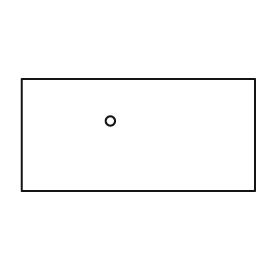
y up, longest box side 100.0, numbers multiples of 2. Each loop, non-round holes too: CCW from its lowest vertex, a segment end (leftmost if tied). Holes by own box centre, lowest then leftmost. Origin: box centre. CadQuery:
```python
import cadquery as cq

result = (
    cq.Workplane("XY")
    .moveTo(-50.0, -24.0)
    .lineTo(50.0, -24.0)
    .lineTo(50.0, 24.0)
    .lineTo(-50.0, 24.0)
    .close()
    .moveTo(-12.0, 6.0)
    .circle(2.0)
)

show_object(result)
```